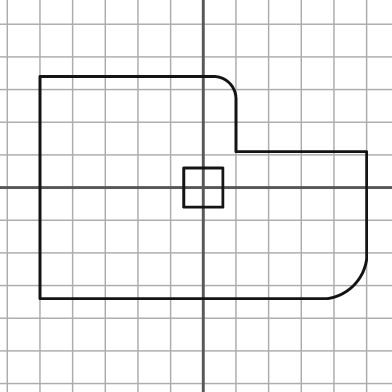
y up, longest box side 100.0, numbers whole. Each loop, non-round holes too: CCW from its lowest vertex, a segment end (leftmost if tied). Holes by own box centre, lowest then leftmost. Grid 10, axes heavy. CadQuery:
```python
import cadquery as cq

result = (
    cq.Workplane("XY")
    .moveTo(-50.0, -34.0)
    .lineTo(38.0, -34.0)
    .threePointArc((46.0, -30.0), (50.0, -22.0))
    .lineTo(50.0, 11.0)
    .lineTo(10.0, 11.0)
    .lineTo(10.0, 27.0)
    .threePointArc((8.0, 32.0), (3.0, 34.0))
    .lineTo(-50.0, 34.0)
    .close()
    .moveTo(-6.0, -6.0)
    .lineTo(6.0, -6.0)
    .lineTo(6.0, 6.0)
    .lineTo(-6.0, 6.0)
    .close()
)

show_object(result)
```